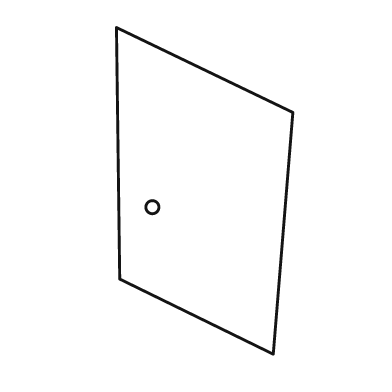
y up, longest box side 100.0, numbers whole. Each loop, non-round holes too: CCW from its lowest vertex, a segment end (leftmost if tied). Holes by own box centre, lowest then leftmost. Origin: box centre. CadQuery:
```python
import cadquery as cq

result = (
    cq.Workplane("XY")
    .moveTo(21.0, -50.0)
    .lineTo(27.0, 24.0)
    .lineTo(-27.0, 50.0)
    .lineTo(-26.0, -27.0)
    .close()
    .moveTo(-16.0, -5.0)
    .circle(2.0)
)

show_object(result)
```